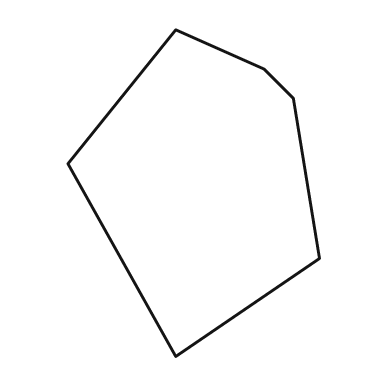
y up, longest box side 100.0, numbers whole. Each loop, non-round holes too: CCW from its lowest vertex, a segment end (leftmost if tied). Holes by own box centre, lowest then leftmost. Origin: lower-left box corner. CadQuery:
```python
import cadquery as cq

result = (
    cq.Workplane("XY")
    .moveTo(33.0, 0.0)
    .lineTo(77.0, 30.0)
    .lineTo(69.0, 79.0)
    .lineTo(60.0, 88.0)
    .lineTo(33.0, 100.0)
    .lineTo(0.0, 59.0)
    .close()
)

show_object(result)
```